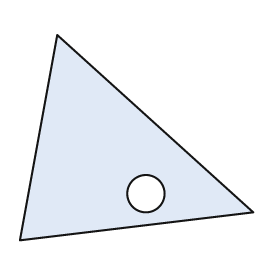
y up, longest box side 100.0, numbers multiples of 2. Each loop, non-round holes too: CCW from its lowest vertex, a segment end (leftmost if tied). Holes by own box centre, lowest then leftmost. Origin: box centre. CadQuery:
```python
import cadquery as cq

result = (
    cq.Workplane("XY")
    .moveTo(-50.0, -44.0)
    .lineTo(50.0, -32.0)
    .lineTo(-34.0, 44.0)
    .close()
    .moveTo(4.0, -24.0)
    .circle(8.0)
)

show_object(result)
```